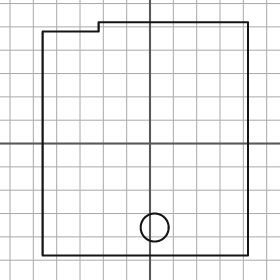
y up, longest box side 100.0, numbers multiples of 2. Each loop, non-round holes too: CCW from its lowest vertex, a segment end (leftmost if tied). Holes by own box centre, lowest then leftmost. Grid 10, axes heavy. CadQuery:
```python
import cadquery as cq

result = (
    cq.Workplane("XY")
    .moveTo(-46.0, -48.0)
    .lineTo(42.0, -48.0)
    .lineTo(42.0, 52.0)
    .lineTo(-22.0, 52.0)
    .lineTo(-22.0, 48.0)
    .lineTo(-46.0, 48.0)
    .close()
    .moveTo(2.0, -36.0)
    .circle(6.0)
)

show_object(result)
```